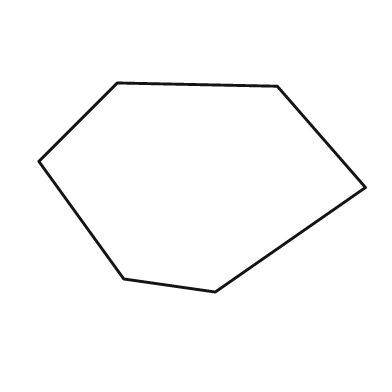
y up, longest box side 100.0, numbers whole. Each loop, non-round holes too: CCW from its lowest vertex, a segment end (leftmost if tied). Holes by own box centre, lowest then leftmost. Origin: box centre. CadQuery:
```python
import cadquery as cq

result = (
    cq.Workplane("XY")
    .moveTo(4.0, -32.0)
    .lineTo(50.0, 0.0)
    .lineTo(23.0, 31.0)
    .lineTo(-26.0, 32.0)
    .lineTo(-50.0, 8.0)
    .lineTo(-24.0, -28.0)
    .close()
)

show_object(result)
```